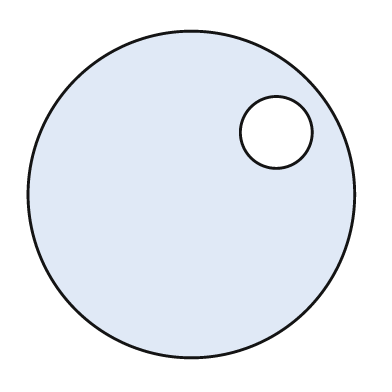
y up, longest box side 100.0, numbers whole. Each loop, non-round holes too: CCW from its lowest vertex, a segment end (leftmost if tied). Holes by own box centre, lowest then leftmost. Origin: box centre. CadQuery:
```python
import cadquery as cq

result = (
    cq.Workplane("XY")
    .moveTo(0.0, 0.0)
    .circle(50.0)
    .moveTo(26.0, 19.0)
    .circle(11.0)
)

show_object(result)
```